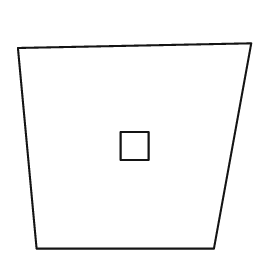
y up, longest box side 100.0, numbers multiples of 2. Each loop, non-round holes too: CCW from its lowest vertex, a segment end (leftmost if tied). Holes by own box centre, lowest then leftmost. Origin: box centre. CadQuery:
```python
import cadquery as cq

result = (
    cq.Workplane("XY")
    .moveTo(-42.0, -44.0)
    .lineTo(34.0, -44.0)
    .lineTo(50.0, 44.0)
    .lineTo(-50.0, 42.0)
    .close()
    .moveTo(-6.0, -6.0)
    .lineTo(6.0, -6.0)
    .lineTo(6.0, 6.0)
    .lineTo(-6.0, 6.0)
    .close()
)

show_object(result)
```